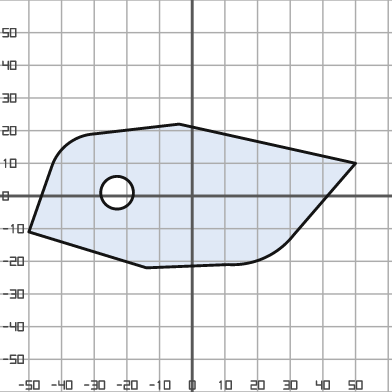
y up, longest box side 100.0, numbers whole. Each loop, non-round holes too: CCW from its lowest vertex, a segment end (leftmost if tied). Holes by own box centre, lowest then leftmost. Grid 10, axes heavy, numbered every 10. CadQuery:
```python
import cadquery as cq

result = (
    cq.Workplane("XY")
    .moveTo(-14.0, -22.0)
    .lineTo(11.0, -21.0)
    .threePointArc((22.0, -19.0), (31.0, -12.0))
    .lineTo(50.0, 10.0)
    .lineTo(-4.0, 22.0)
    .lineTo(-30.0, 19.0)
    .threePointArc((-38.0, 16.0), (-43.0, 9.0))
    .lineTo(-50.0, -11.0)
    .close()
    .moveTo(-23.0, 1.0)
    .circle(5.0)
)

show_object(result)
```